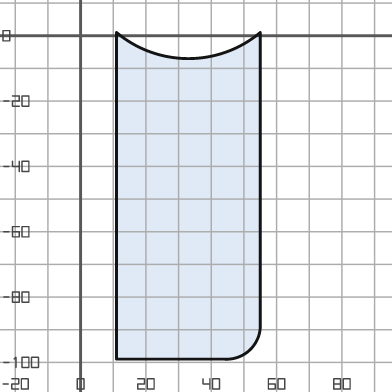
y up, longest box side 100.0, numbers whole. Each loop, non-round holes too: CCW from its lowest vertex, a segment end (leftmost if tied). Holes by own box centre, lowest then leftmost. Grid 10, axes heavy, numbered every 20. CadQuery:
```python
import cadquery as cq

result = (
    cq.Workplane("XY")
    .moveTo(11.0, -99.0)
    .lineTo(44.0, -99.0)
    .threePointArc((52.0, -96.0), (55.0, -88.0))
    .lineTo(55.0, 1.0)
    .threePointArc((33.0, -7.0), (11.0, 1.0))
    .close()
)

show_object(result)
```